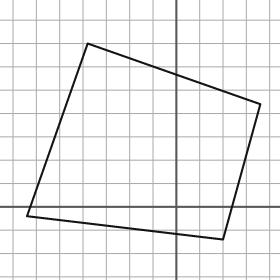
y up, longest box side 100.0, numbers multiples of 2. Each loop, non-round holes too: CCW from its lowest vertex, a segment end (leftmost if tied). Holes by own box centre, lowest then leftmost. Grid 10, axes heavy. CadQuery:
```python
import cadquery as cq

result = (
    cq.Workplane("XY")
    .moveTo(20.0, -14.0)
    .lineTo(36.0, 44.0)
    .lineTo(-38.0, 70.0)
    .lineTo(-64.0, -4.0)
    .close()
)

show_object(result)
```